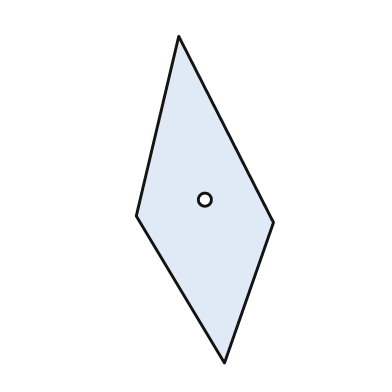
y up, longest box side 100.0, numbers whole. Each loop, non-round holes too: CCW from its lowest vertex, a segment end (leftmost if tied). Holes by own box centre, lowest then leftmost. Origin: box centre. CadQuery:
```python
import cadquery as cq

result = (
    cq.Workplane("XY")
    .moveTo(6.0, -50.0)
    .lineTo(21.0, -7.0)
    .lineTo(-8.0, 50.0)
    .lineTo(-21.0, -5.0)
    .close()
    .moveTo(0.0, 0.0)
    .circle(2.0)
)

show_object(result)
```